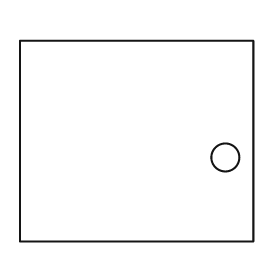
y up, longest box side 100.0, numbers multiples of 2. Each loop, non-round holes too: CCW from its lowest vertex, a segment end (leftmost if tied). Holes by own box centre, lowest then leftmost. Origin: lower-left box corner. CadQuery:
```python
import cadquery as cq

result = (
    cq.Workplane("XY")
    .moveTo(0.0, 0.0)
    .lineTo(100.0, 0.0)
    .lineTo(100.0, 86.0)
    .lineTo(0.0, 86.0)
    .close()
    .moveTo(88.0, 36.0)
    .circle(6.0)
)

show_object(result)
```